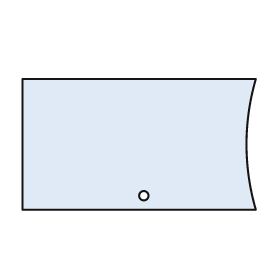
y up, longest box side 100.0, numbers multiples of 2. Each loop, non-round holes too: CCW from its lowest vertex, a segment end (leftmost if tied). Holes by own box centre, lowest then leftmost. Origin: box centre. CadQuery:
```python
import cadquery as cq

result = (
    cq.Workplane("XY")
    .moveTo(-50.0, -28.0)
    .lineTo(50.0, -28.0)
    .threePointArc((46.0, 0.0), (50.0, 28.0))
    .lineTo(-50.0, 28.0)
    .close()
    .moveTo(2.0, -22.0)
    .circle(2.0)
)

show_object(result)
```